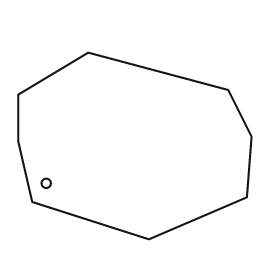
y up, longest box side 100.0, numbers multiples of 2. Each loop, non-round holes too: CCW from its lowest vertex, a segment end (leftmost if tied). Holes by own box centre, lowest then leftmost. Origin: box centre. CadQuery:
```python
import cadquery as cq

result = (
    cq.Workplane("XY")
    .moveTo(6.0, -40.0)
    .lineTo(48.0, -22.0)
    .lineTo(50.0, 4.0)
    .lineTo(40.0, 24.0)
    .lineTo(-20.0, 40.0)
    .lineTo(-50.0, 22.0)
    .lineTo(-50.0, 2.0)
    .lineTo(-44.0, -24.0)
    .close()
    .moveTo(-38.0, -16.0)
    .circle(2.0)
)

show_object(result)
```